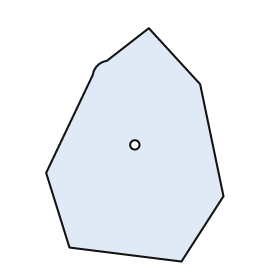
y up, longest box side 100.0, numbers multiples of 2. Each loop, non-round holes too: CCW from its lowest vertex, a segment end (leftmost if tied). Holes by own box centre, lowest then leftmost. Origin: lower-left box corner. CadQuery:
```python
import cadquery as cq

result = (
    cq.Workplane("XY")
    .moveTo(58.0, 0.0)
    .lineTo(76.0, 28.0)
    .lineTo(66.0, 76.0)
    .lineTo(44.0, 100.0)
    .lineTo(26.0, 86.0)
    .threePointArc((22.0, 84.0), (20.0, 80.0))
    .lineTo(0.0, 38.0)
    .lineTo(10.0, 6.0)
    .close()
    .moveTo(38.0, 50.0)
    .circle(2.0)
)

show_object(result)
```